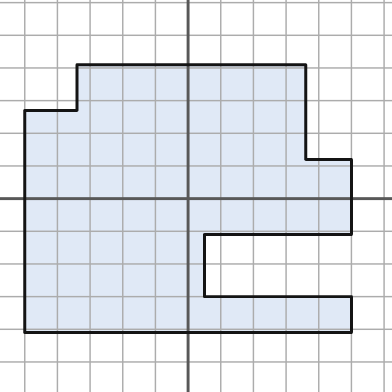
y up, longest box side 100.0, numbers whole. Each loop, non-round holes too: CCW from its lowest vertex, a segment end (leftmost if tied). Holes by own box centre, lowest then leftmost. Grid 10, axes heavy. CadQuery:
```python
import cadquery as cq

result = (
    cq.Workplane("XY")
    .moveTo(-50.0, -41.0)
    .lineTo(50.0, -41.0)
    .lineTo(50.0, -30.0)
    .lineTo(5.0, -30.0)
    .lineTo(5.0, -11.0)
    .lineTo(50.0, -11.0)
    .lineTo(50.0, 12.0)
    .lineTo(36.0, 12.0)
    .lineTo(36.0, 41.0)
    .lineTo(-34.0, 41.0)
    .lineTo(-34.0, 27.0)
    .lineTo(-50.0, 27.0)
    .close()
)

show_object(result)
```